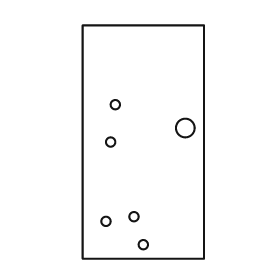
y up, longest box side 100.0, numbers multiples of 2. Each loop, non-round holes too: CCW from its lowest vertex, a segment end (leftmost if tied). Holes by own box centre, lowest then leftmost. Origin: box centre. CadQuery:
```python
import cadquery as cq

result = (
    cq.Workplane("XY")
    .moveTo(-26.0, -50.0)
    .lineTo(26.0, -50.0)
    .lineTo(26.0, 50.0)
    .lineTo(-26.0, 50.0)
    .close()
    .moveTo(0.0, -44.0)
    .circle(2.0)
    .moveTo(-16.0, -34.0)
    .circle(2.0)
    .moveTo(-4.0, -32.0)
    .circle(2.0)
    .moveTo(-14.0, 0.0)
    .circle(2.0)
    .moveTo(18.0, 6.0)
    .circle(4.0)
    .moveTo(-12.0, 16.0)
    .circle(2.0)
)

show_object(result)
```